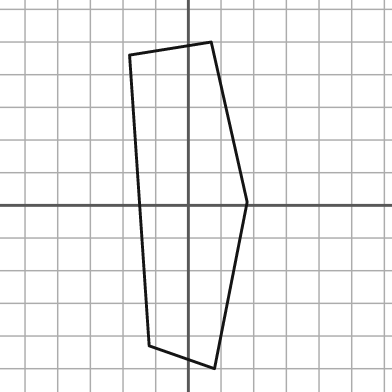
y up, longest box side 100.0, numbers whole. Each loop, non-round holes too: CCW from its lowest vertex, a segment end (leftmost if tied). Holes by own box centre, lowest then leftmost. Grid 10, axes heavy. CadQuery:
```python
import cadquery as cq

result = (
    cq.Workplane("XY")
    .moveTo(8.0, -50.0)
    .lineTo(18.0, 1.0)
    .lineTo(7.0, 50.0)
    .lineTo(-18.0, 46.0)
    .lineTo(-12.0, -43.0)
    .close()
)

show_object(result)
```